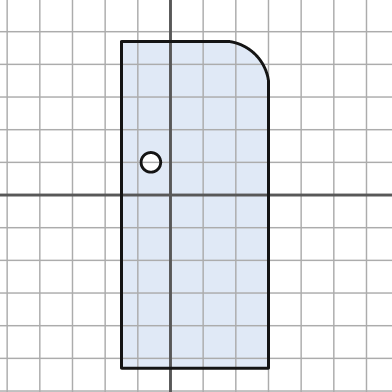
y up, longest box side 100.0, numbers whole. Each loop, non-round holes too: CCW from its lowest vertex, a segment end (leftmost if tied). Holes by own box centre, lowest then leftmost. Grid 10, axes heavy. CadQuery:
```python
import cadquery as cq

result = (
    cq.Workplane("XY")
    .moveTo(-15.0, -53.0)
    .lineTo(30.0, -53.0)
    .lineTo(30.0, 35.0)
    .threePointArc((26.0, 43.0), (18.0, 47.0))
    .lineTo(-15.0, 47.0)
    .close()
    .moveTo(-6.0, 10.0)
    .circle(3.0)
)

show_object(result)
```